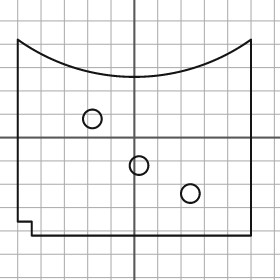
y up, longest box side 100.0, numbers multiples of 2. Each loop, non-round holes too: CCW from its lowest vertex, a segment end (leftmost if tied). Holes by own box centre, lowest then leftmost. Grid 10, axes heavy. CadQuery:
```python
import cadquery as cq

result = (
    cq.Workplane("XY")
    .moveTo(-44.0, -42.0)
    .lineTo(50.0, -42.0)
    .lineTo(50.0, 42.0)
    .threePointArc((0.0, 26.0), (-50.0, 42.0))
    .lineTo(-50.0, -36.0)
    .lineTo(-44.0, -36.0)
    .close()
    .moveTo(24.0, -24.0)
    .circle(4.0)
    .moveTo(2.0, -12.0)
    .circle(4.0)
    .moveTo(-18.0, 8.0)
    .circle(4.0)
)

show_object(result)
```